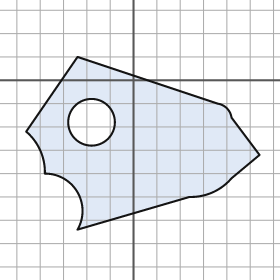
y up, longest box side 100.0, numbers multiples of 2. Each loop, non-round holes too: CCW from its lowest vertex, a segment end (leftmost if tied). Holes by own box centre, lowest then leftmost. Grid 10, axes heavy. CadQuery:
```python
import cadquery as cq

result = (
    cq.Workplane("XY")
    .moveTo(-24.0, -64.0)
    .lineTo(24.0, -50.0)
    .threePointArc((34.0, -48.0), (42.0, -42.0))
    .lineTo(54.0, -32.0)
    .lineTo(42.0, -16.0)
    .threePointArc((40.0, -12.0), (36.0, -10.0))
    .lineTo(-24.0, 10.0)
    .lineTo(-46.0, -22.0)
    .threePointArc((-40.0, -30.0), (-38.0, -40.0))
    .threePointArc((-24.0, -48.0), (-24.0, -64.0))
    .close()
    .moveTo(-18.0, -18.0)
    .circle(10.0)
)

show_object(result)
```